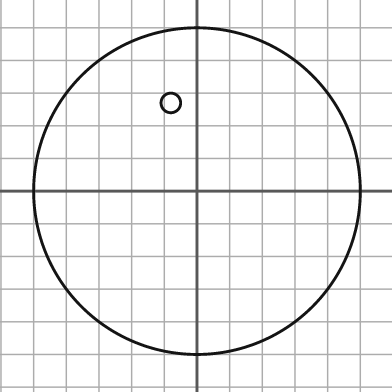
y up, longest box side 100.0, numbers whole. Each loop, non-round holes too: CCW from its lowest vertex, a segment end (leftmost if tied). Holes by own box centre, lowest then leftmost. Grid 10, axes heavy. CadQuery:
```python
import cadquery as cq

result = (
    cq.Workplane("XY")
    .moveTo(0.0, 0.0)
    .circle(50.0)
    .moveTo(-8.0, 27.0)
    .circle(3.0)
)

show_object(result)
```